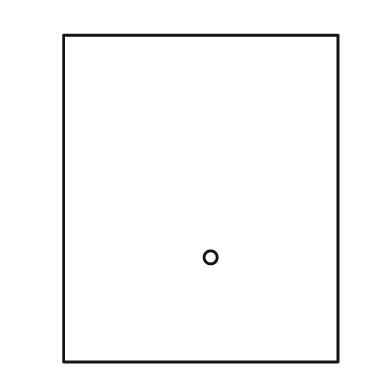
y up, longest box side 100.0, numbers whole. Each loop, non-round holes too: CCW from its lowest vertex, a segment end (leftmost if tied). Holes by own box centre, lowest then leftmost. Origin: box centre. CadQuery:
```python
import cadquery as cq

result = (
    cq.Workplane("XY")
    .moveTo(-42.0, -50.0)
    .lineTo(42.0, -50.0)
    .lineTo(42.0, 50.0)
    .lineTo(-42.0, 50.0)
    .close()
    .moveTo(3.0, -18.0)
    .circle(2.0)
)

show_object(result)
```